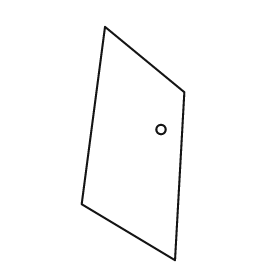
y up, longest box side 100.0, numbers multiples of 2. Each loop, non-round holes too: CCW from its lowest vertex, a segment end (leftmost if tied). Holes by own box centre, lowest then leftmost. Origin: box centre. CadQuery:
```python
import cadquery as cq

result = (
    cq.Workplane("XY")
    .moveTo(18.0, -50.0)
    .lineTo(22.0, 22.0)
    .lineTo(-12.0, 50.0)
    .lineTo(-22.0, -26.0)
    .close()
    .moveTo(12.0, 6.0)
    .circle(2.0)
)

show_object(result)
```